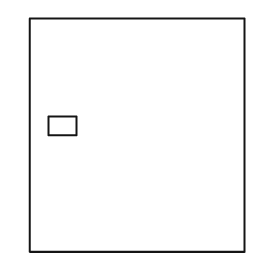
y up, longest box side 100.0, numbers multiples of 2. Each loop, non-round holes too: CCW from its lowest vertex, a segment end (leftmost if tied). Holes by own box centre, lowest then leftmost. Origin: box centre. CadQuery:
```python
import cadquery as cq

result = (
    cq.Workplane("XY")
    .moveTo(-46.0, -50.0)
    .lineTo(46.0, -50.0)
    .lineTo(46.0, 50.0)
    .lineTo(-46.0, 50.0)
    .close()
    .moveTo(-38.0, 0.0)
    .lineTo(-26.0, 0.0)
    .lineTo(-26.0, 8.0)
    .lineTo(-38.0, 8.0)
    .close()
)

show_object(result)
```